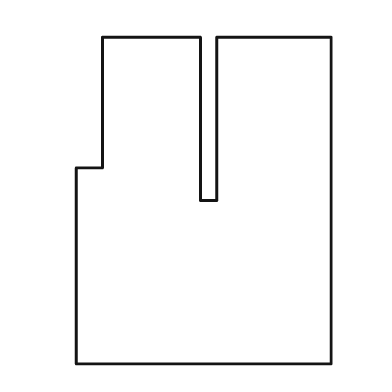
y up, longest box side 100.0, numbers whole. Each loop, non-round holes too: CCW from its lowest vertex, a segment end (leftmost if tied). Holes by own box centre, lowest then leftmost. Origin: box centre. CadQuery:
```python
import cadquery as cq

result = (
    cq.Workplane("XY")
    .moveTo(-39.0, -50.0)
    .lineTo(39.0, -50.0)
    .lineTo(39.0, 50.0)
    .lineTo(4.0, 50.0)
    .lineTo(4.0, 0.0)
    .lineTo(-1.0, 0.0)
    .lineTo(-1.0, 50.0)
    .lineTo(-31.0, 50.0)
    .lineTo(-31.0, 10.0)
    .lineTo(-39.0, 10.0)
    .close()
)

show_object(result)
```